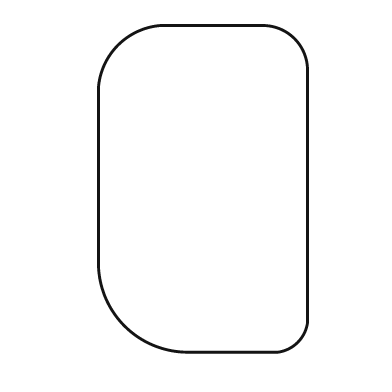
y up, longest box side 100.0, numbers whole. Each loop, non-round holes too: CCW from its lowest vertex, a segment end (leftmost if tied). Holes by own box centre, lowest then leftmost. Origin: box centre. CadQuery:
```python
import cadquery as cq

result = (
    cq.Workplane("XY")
    .moveTo(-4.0, -50.0)
    .lineTo(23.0, -50.0)
    .threePointArc((29.0, -47.0), (32.0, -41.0))
    .lineTo(32.0, 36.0)
    .threePointArc((28.0, 46.0), (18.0, 50.0))
    .lineTo(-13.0, 50.0)
    .threePointArc((-26.0, 44.0), (-32.0, 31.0))
    .lineTo(-32.0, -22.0)
    .threePointArc((-24.0, -42.0), (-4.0, -50.0))
    .close()
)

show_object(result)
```